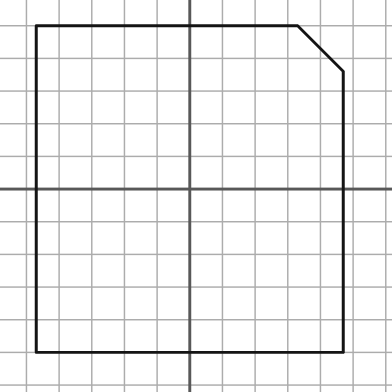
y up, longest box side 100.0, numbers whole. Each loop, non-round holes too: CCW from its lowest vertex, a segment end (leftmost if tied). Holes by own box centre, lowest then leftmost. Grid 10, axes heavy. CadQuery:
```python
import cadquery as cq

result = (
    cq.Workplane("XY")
    .moveTo(-47.0, -50.0)
    .lineTo(47.0, -50.0)
    .lineTo(47.0, 36.0)
    .lineTo(33.0, 50.0)
    .lineTo(-47.0, 50.0)
    .close()
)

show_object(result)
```